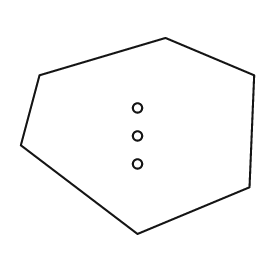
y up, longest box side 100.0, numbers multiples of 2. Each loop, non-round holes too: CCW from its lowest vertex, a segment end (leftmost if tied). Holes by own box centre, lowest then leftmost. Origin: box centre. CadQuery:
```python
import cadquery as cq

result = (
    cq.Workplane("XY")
    .moveTo(0.0, -42.0)
    .lineTo(48.0, -22.0)
    .lineTo(50.0, 26.0)
    .lineTo(12.0, 42.0)
    .lineTo(-42.0, 26.0)
    .lineTo(-50.0, -4.0)
    .close()
    .moveTo(0.0, -12.0)
    .circle(2.0)
    .moveTo(0.0, 0.0)
    .circle(2.0)
    .moveTo(0.0, 12.0)
    .circle(2.0)
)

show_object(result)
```